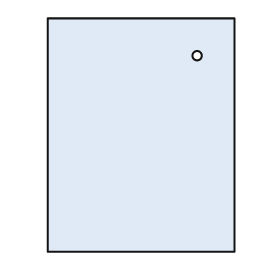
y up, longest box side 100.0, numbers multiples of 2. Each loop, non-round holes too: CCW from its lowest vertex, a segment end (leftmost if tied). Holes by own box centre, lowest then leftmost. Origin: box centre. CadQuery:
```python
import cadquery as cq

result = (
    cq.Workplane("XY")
    .moveTo(-40.0, -50.0)
    .lineTo(40.0, -50.0)
    .lineTo(40.0, 50.0)
    .lineTo(-40.0, 50.0)
    .close()
    .moveTo(24.0, 34.0)
    .circle(2.0)
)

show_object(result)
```